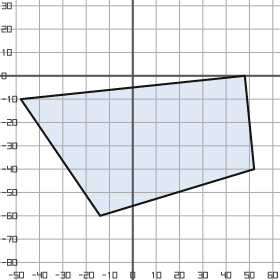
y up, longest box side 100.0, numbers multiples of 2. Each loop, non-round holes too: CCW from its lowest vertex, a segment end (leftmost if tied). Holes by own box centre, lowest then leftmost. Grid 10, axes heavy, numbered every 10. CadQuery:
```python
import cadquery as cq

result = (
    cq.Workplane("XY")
    .moveTo(-14.0, -60.0)
    .lineTo(52.0, -40.0)
    .lineTo(48.0, 0.0)
    .lineTo(-48.0, -10.0)
    .close()
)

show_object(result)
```